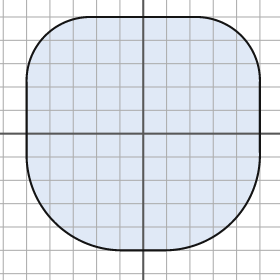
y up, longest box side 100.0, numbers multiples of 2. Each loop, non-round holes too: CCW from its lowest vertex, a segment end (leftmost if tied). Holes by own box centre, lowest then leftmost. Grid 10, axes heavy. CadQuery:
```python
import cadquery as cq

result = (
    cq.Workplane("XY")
    .moveTo(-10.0, -50.0)
    .lineTo(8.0, -50.0)
    .threePointArc((38.0, -38.0), (50.0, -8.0))
    .lineTo(50.0, 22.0)
    .threePointArc((42.0, 42.0), (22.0, 50.0))
    .lineTo(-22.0, 50.0)
    .threePointArc((-42.0, 42.0), (-50.0, 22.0))
    .lineTo(-50.0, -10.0)
    .threePointArc((-38.0, -38.0), (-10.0, -50.0))
    .close()
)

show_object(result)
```